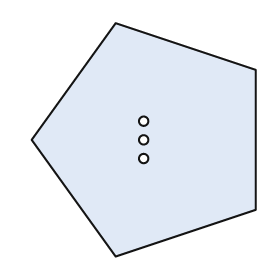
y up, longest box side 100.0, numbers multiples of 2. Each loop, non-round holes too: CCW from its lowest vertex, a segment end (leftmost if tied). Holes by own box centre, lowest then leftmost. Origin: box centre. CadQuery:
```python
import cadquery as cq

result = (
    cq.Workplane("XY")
    .moveTo(-12.0, -50.0)
    .lineTo(48.0, -30.0)
    .lineTo(48.0, 30.0)
    .lineTo(-12.0, 50.0)
    .lineTo(-48.0, 0.0)
    .close()
    .moveTo(0.0, -8.0)
    .circle(2.0)
    .moveTo(0.0, 0.0)
    .circle(2.0)
    .moveTo(0.0, 8.0)
    .circle(2.0)
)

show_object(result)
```